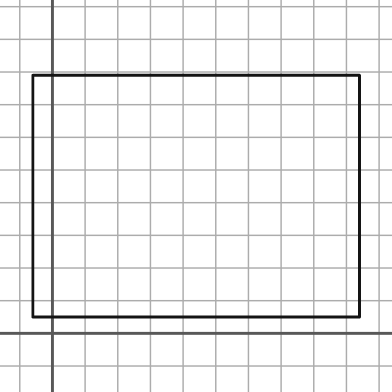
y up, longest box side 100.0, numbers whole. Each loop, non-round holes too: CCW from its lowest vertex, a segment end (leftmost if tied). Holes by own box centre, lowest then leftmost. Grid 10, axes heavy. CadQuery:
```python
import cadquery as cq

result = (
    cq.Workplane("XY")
    .moveTo(-6.0, 5.0)
    .lineTo(94.0, 5.0)
    .lineTo(94.0, 79.0)
    .lineTo(-6.0, 79.0)
    .close()
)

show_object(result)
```